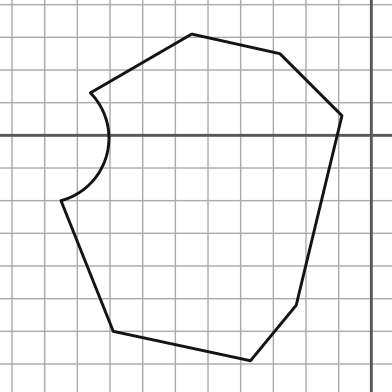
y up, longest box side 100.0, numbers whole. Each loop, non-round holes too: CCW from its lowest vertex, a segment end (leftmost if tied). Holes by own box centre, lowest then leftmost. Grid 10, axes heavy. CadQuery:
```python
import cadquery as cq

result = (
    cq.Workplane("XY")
    .moveTo(-37.0, -69.0)
    .lineTo(-23.0, -52.0)
    .lineTo(-9.0, 6.0)
    .lineTo(-28.0, 25.0)
    .lineTo(-55.0, 31.0)
    .lineTo(-86.0, 13.0)
    .threePointArc((-81.0, -6.0), (-95.0, -20.0))
    .lineTo(-79.0, -60.0)
    .close()
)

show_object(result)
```